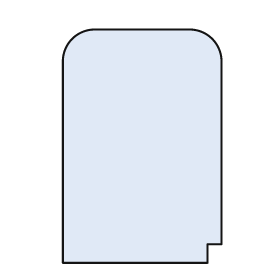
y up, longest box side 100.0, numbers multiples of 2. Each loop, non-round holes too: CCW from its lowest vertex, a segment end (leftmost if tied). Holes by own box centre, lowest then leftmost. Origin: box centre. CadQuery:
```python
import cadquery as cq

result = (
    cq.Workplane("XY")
    .moveTo(-34.0, -50.0)
    .lineTo(28.0, -50.0)
    .lineTo(28.0, -42.0)
    .lineTo(34.0, -42.0)
    .lineTo(34.0, 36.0)
    .threePointArc((30.0, 46.0), (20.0, 50.0))
    .lineTo(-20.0, 50.0)
    .threePointArc((-30.0, 46.0), (-34.0, 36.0))
    .close()
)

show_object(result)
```